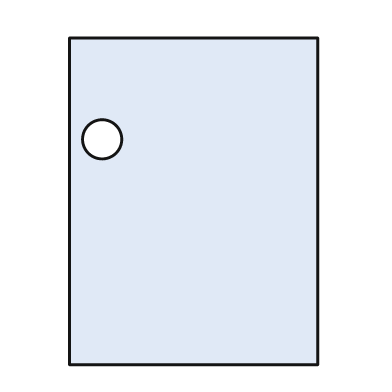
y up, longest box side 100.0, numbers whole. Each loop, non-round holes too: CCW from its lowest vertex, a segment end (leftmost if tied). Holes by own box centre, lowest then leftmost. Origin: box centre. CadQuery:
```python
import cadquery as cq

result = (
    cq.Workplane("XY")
    .moveTo(-38.0, -50.0)
    .lineTo(38.0, -50.0)
    .lineTo(38.0, 50.0)
    .lineTo(-38.0, 50.0)
    .close()
    .moveTo(-28.0, 19.0)
    .circle(6.0)
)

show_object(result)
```